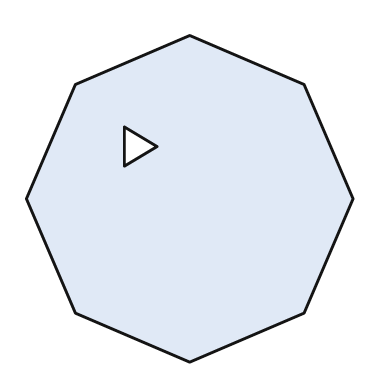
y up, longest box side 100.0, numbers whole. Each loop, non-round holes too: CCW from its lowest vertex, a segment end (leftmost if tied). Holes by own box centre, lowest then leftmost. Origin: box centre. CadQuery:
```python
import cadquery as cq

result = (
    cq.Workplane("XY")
    .moveTo(0.0, -50.0)
    .lineTo(35.0, -35.0)
    .lineTo(50.0, 0.0)
    .lineTo(35.0, 35.0)
    .lineTo(0.0, 50.0)
    .lineTo(-35.0, 35.0)
    .lineTo(-50.0, 0.0)
    .lineTo(-35.0, -35.0)
    .close()
    .moveTo(-20.0, 10.0)
    .lineTo(-10.0, 16.0)
    .lineTo(-20.0, 22.0)
    .close()
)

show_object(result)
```